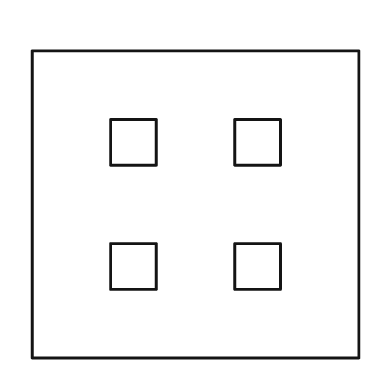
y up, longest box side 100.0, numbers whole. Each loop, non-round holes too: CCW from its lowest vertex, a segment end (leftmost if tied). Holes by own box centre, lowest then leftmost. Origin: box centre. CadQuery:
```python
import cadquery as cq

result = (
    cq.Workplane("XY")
    .moveTo(-50.0, -47.0)
    .lineTo(50.0, -47.0)
    .lineTo(50.0, 47.0)
    .lineTo(-50.0, 47.0)
    .close()
    .moveTo(-26.0, -26.0)
    .lineTo(-12.0, -26.0)
    .lineTo(-12.0, -12.0)
    .lineTo(-26.0, -12.0)
    .close()
    .moveTo(12.0, -26.0)
    .lineTo(26.0, -26.0)
    .lineTo(26.0, -12.0)
    .lineTo(12.0, -12.0)
    .close()
    .moveTo(-26.0, 12.0)
    .lineTo(-12.0, 12.0)
    .lineTo(-12.0, 26.0)
    .lineTo(-26.0, 26.0)
    .close()
    .moveTo(12.0, 12.0)
    .lineTo(26.0, 12.0)
    .lineTo(26.0, 26.0)
    .lineTo(12.0, 26.0)
    .close()
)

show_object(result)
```